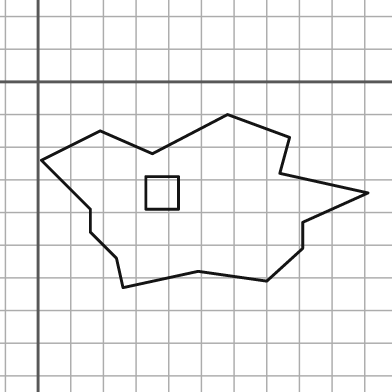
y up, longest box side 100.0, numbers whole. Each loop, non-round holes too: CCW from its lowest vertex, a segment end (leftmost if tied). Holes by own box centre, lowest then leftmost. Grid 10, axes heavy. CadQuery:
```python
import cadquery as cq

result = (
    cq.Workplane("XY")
    .moveTo(26.0, -63.0)
    .lineTo(49.0, -58.0)
    .lineTo(70.0, -61.0)
    .lineTo(81.0, -51.0)
    .lineTo(81.0, -43.0)
    .lineTo(101.0, -34.0)
    .lineTo(74.0, -28.0)
    .lineTo(77.0, -17.0)
    .lineTo(58.0, -10.0)
    .lineTo(35.0, -22.0)
    .lineTo(19.0, -15.0)
    .lineTo(1.0, -24.0)
    .lineTo(16.0, -39.0)
    .lineTo(16.0, -46.0)
    .lineTo(24.0, -54.0)
    .close()
    .moveTo(33.0, -39.0)
    .lineTo(43.0, -39.0)
    .lineTo(43.0, -29.0)
    .lineTo(33.0, -29.0)
    .close()
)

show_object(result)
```